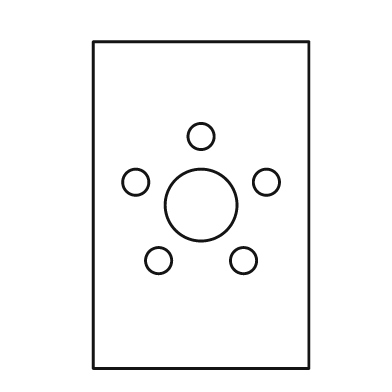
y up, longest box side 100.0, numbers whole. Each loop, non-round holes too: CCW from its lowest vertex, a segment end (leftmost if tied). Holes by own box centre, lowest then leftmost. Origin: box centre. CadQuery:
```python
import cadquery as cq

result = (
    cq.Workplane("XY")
    .moveTo(-33.0, -50.0)
    .lineTo(33.0, -50.0)
    .lineTo(33.0, 50.0)
    .lineTo(-33.0, 50.0)
    .close()
    .moveTo(-13.0, -17.0)
    .circle(4.0)
    .moveTo(13.0, -17.0)
    .circle(4.0)
    .moveTo(0.0, 0.0)
    .circle(11.0)
    .moveTo(-20.0, 7.0)
    .circle(4.0)
    .moveTo(20.0, 7.0)
    .circle(4.0)
    .moveTo(0.0, 21.0)
    .circle(4.0)
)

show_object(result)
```